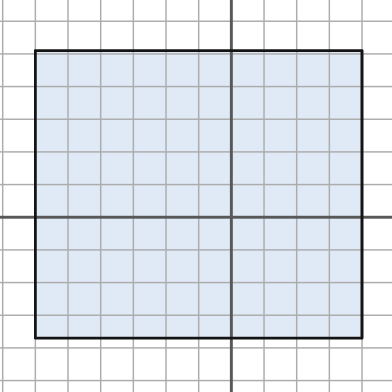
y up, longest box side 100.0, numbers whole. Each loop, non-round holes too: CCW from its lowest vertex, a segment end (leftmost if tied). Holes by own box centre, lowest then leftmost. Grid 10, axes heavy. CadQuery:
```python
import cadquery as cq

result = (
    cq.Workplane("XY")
    .moveTo(-60.0, -37.0)
    .lineTo(40.0, -37.0)
    .lineTo(40.0, 51.0)
    .lineTo(-60.0, 51.0)
    .close()
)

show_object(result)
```